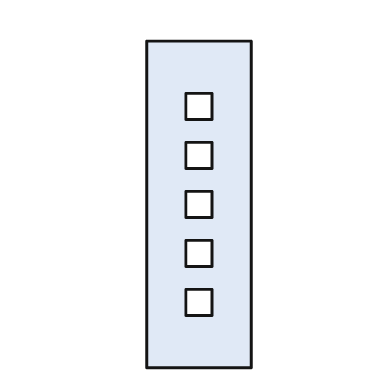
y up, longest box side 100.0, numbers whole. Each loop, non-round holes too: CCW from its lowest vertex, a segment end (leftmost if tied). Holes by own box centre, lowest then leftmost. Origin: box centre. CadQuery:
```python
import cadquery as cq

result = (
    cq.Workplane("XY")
    .moveTo(-16.0, -50.0)
    .lineTo(16.0, -50.0)
    .lineTo(16.0, 50.0)
    .lineTo(-16.0, 50.0)
    .close()
    .moveTo(-4.0, -34.0)
    .lineTo(4.0, -34.0)
    .lineTo(4.0, -26.0)
    .lineTo(-4.0, -26.0)
    .close()
    .moveTo(-4.0, -19.0)
    .lineTo(4.0, -19.0)
    .lineTo(4.0, -11.0)
    .lineTo(-4.0, -11.0)
    .close()
    .moveTo(-4.0, -4.0)
    .lineTo(4.0, -4.0)
    .lineTo(4.0, 4.0)
    .lineTo(-4.0, 4.0)
    .close()
    .moveTo(-4.0, 11.0)
    .lineTo(4.0, 11.0)
    .lineTo(4.0, 19.0)
    .lineTo(-4.0, 19.0)
    .close()
    .moveTo(-4.0, 26.0)
    .lineTo(4.0, 26.0)
    .lineTo(4.0, 34.0)
    .lineTo(-4.0, 34.0)
    .close()
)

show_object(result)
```